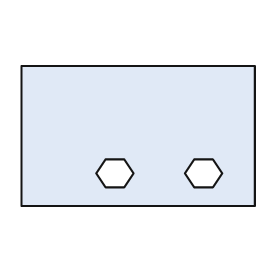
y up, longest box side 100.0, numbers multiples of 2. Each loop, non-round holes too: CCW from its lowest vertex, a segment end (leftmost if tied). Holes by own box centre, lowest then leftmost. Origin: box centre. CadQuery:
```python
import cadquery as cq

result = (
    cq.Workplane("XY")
    .moveTo(-50.0, -30.0)
    .lineTo(50.0, -30.0)
    .lineTo(50.0, 30.0)
    .lineTo(-50.0, 30.0)
    .close()
    .moveTo(-14.0, -22.0)
    .lineTo(-6.0, -22.0)
    .lineTo(-2.0, -16.0)
    .lineTo(-6.0, -10.0)
    .lineTo(-14.0, -10.0)
    .lineTo(-18.0, -16.0)
    .close()
    .moveTo(24.0, -22.0)
    .lineTo(32.0, -22.0)
    .lineTo(36.0, -16.0)
    .lineTo(32.0, -10.0)
    .lineTo(24.0, -10.0)
    .lineTo(20.0, -16.0)
    .close()
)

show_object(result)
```